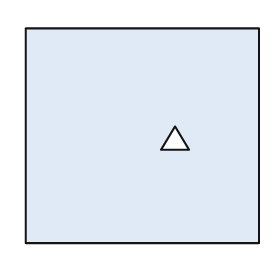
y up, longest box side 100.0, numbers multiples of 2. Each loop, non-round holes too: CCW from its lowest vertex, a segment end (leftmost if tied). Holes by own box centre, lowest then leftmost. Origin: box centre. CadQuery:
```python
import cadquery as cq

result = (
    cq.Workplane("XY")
    .moveTo(-50.0, -46.0)
    .lineTo(50.0, -46.0)
    .lineTo(50.0, 46.0)
    .lineTo(-50.0, 46.0)
    .close()
    .moveTo(8.0, -6.0)
    .lineTo(20.0, -6.0)
    .lineTo(14.0, 4.0)
    .close()
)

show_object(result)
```